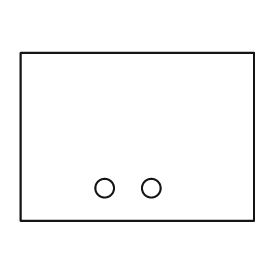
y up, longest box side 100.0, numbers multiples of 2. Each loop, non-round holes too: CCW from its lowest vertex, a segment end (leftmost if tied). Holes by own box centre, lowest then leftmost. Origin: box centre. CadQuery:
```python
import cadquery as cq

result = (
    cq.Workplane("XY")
    .moveTo(-50.0, -36.0)
    .lineTo(50.0, -36.0)
    .lineTo(50.0, 36.0)
    .lineTo(-50.0, 36.0)
    .close()
    .moveTo(-14.0, -22.0)
    .circle(4.0)
    .moveTo(6.0, -22.0)
    .circle(4.0)
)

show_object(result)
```